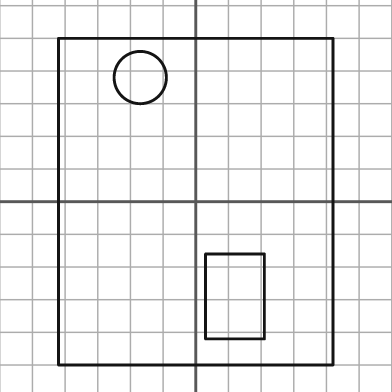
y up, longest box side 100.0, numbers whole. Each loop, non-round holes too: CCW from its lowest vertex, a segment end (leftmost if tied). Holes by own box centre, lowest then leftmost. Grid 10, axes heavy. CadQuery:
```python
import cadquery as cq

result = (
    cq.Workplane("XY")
    .moveTo(-42.0, -50.0)
    .lineTo(42.0, -50.0)
    .lineTo(42.0, 50.0)
    .lineTo(-42.0, 50.0)
    .close()
    .moveTo(3.0, -42.0)
    .lineTo(21.0, -42.0)
    .lineTo(21.0, -16.0)
    .lineTo(3.0, -16.0)
    .close()
    .moveTo(-17.0, 38.0)
    .circle(8.0)
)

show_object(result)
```